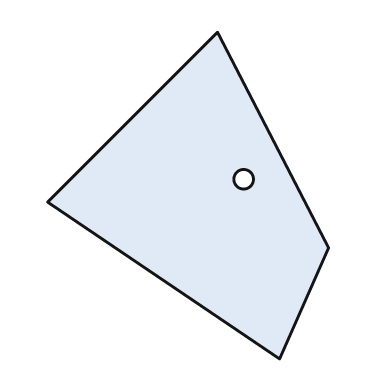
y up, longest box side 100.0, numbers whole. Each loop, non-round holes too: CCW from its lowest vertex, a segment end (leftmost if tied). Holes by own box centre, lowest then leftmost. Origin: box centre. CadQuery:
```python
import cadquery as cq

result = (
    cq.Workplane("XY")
    .moveTo(28.0, -50.0)
    .lineTo(43.0, -16.0)
    .lineTo(9.0, 50.0)
    .lineTo(-43.0, -2.0)
    .close()
    .moveTo(17.0, 5.0)
    .circle(3.0)
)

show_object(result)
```